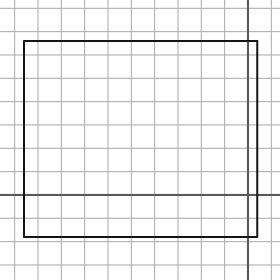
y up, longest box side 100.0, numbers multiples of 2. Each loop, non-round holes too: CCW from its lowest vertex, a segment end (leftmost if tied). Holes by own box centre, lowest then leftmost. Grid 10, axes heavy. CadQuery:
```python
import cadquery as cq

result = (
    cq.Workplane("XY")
    .moveTo(-96.0, -18.0)
    .lineTo(4.0, -18.0)
    .lineTo(4.0, 66.0)
    .lineTo(-96.0, 66.0)
    .close()
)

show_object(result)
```